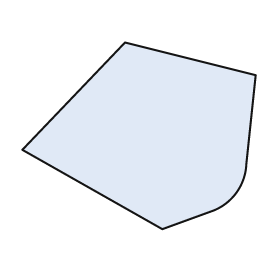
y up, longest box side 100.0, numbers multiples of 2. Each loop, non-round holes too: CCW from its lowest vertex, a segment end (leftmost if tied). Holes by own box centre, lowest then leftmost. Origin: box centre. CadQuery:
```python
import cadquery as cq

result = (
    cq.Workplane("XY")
    .moveTo(10.0, -40.0)
    .lineTo(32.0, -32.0)
    .threePointArc((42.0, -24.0), (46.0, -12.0))
    .lineTo(50.0, 26.0)
    .lineTo(-6.0, 40.0)
    .lineTo(-50.0, -6.0)
    .close()
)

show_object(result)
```